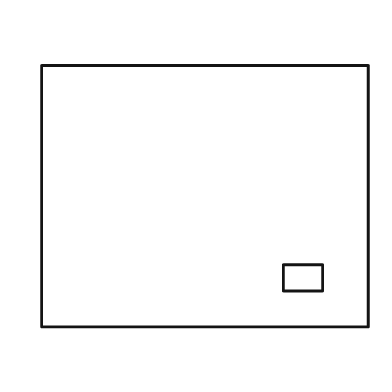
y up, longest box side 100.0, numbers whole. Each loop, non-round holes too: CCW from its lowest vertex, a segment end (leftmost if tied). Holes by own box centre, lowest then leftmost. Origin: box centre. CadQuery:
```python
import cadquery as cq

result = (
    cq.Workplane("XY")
    .moveTo(-50.0, -40.0)
    .lineTo(50.0, -40.0)
    .lineTo(50.0, 40.0)
    .lineTo(-50.0, 40.0)
    .close()
    .moveTo(24.0, -29.0)
    .lineTo(36.0, -29.0)
    .lineTo(36.0, -21.0)
    .lineTo(24.0, -21.0)
    .close()
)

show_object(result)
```